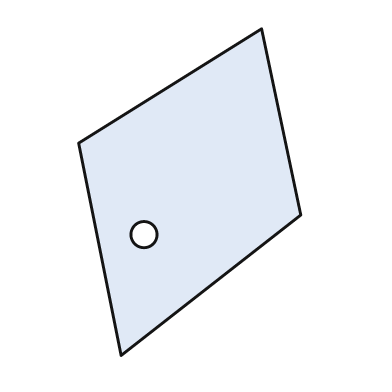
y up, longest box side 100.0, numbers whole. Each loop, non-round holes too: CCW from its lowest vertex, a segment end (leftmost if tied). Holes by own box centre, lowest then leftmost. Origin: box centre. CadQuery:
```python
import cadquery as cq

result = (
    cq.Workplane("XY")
    .moveTo(-21.0, -50.0)
    .lineTo(34.0, -7.0)
    .lineTo(22.0, 50.0)
    .lineTo(-34.0, 15.0)
    .close()
    .moveTo(-14.0, -13.0)
    .circle(4.0)
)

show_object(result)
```